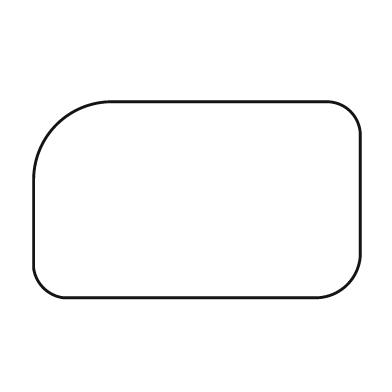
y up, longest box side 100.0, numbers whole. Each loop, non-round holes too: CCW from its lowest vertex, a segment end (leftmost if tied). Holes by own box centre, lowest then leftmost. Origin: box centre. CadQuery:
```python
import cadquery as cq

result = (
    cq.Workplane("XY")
    .moveTo(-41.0, -30.0)
    .lineTo(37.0, -30.0)
    .threePointArc((46.0, -26.0), (50.0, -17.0))
    .lineTo(50.0, 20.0)
    .threePointArc((47.0, 27.0), (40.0, 30.0))
    .lineTo(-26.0, 30.0)
    .threePointArc((-43.0, 23.0), (-50.0, 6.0))
    .lineTo(-50.0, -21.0)
    .threePointArc((-47.0, -27.0), (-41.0, -30.0))
    .close()
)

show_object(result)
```